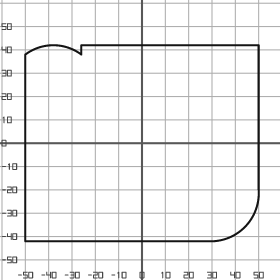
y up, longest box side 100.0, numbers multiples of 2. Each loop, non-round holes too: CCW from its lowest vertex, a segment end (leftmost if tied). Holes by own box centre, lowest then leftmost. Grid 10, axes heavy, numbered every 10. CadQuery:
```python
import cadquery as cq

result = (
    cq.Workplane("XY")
    .moveTo(-50.0, -42.0)
    .lineTo(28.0, -42.0)
    .threePointArc((44.0, -36.0), (50.0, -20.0))
    .lineTo(50.0, 42.0)
    .lineTo(-26.0, 42.0)
    .lineTo(-26.0, 38.0)
    .threePointArc((-38.0, 42.0), (-50.0, 38.0))
    .close()
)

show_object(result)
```